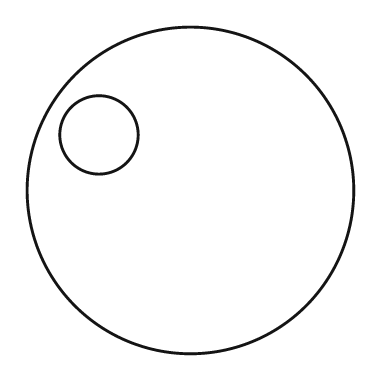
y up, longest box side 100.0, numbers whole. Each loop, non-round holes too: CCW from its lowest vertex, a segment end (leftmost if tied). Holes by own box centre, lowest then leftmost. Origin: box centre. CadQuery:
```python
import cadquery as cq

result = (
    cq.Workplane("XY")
    .moveTo(0.0, 0.0)
    .circle(50.0)
    .moveTo(-28.0, 17.0)
    .circle(12.0)
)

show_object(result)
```